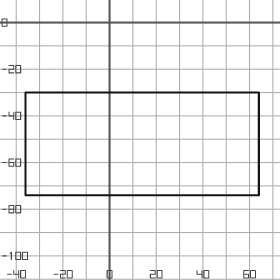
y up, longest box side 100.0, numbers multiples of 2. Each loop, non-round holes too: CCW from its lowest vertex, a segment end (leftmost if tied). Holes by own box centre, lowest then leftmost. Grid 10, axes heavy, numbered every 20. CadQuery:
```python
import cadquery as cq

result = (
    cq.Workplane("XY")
    .moveTo(-36.0, -74.0)
    .lineTo(64.0, -74.0)
    .lineTo(64.0, -30.0)
    .lineTo(-36.0, -30.0)
    .close()
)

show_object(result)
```